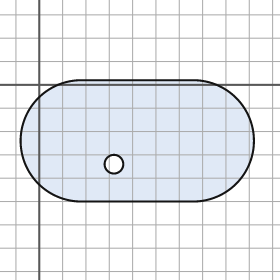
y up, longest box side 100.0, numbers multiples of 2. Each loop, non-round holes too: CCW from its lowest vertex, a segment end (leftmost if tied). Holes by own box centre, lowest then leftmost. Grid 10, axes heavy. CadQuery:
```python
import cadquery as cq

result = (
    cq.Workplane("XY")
    .moveTo(18.0, -50.0)
    .lineTo(66.0, -50.0)
    .threePointArc((92.0, -24.0), (66.0, 2.0))
    .lineTo(18.0, 2.0)
    .threePointArc((-8.0, -24.0), (18.0, -50.0))
    .close()
    .moveTo(32.0, -34.0)
    .circle(4.0)
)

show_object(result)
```